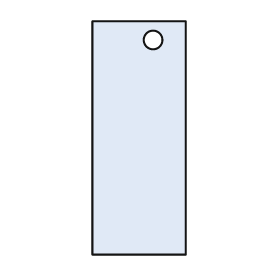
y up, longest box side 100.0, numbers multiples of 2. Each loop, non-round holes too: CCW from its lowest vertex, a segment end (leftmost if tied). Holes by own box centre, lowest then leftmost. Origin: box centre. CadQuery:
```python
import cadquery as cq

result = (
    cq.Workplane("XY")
    .moveTo(-20.0, -50.0)
    .lineTo(20.0, -50.0)
    .lineTo(20.0, 50.0)
    .lineTo(-20.0, 50.0)
    .close()
    .moveTo(6.0, 42.0)
    .circle(4.0)
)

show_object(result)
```